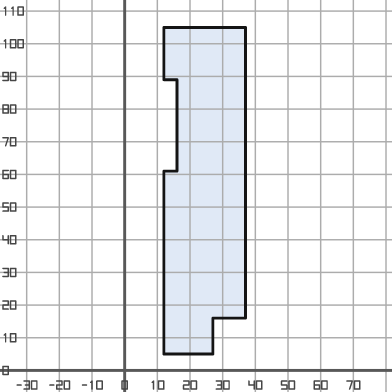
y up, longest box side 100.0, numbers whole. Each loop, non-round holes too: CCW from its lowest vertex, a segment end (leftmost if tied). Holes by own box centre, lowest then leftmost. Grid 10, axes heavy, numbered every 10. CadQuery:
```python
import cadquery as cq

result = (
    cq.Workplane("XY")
    .moveTo(12.0, 5.0)
    .lineTo(27.0, 5.0)
    .lineTo(27.0, 16.0)
    .lineTo(37.0, 16.0)
    .lineTo(37.0, 105.0)
    .lineTo(12.0, 105.0)
    .lineTo(12.0, 89.0)
    .lineTo(16.0, 89.0)
    .lineTo(16.0, 61.0)
    .lineTo(12.0, 61.0)
    .close()
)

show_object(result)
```